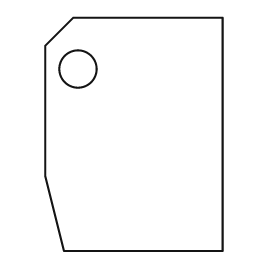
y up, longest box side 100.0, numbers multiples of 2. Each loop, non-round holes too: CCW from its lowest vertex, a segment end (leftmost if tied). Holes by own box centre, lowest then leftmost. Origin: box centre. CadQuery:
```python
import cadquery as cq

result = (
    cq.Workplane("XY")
    .moveTo(-30.0, -50.0)
    .lineTo(38.0, -50.0)
    .lineTo(38.0, 50.0)
    .lineTo(-26.0, 50.0)
    .lineTo(-38.0, 38.0)
    .lineTo(-38.0, -18.0)
    .close()
    .moveTo(-24.0, 28.0)
    .circle(8.0)
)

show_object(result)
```